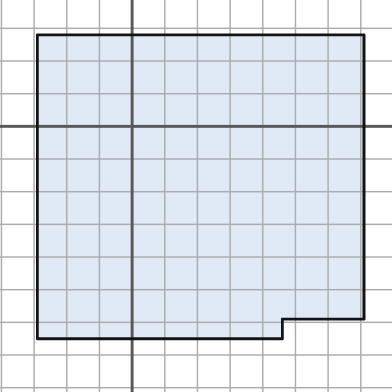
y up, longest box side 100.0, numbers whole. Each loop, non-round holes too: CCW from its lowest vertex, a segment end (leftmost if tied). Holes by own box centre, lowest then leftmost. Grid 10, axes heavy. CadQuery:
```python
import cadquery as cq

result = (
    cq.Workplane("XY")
    .moveTo(-29.0, -65.0)
    .lineTo(46.0, -65.0)
    .lineTo(46.0, -59.0)
    .lineTo(71.0, -59.0)
    .lineTo(71.0, 28.0)
    .lineTo(-29.0, 28.0)
    .close()
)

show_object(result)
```